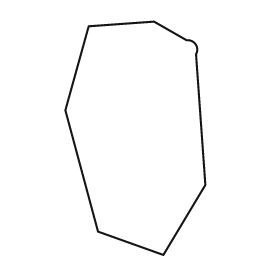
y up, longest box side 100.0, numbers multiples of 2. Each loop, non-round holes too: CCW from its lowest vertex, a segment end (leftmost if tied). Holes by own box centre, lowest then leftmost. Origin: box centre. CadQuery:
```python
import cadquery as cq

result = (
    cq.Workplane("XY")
    .moveTo(12.0, -50.0)
    .lineTo(30.0, -20.0)
    .lineTo(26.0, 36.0)
    .threePointArc((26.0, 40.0), (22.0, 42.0))
    .lineTo(8.0, 50.0)
    .lineTo(-20.0, 48.0)
    .lineTo(-30.0, 12.0)
    .lineTo(-16.0, -40.0)
    .close()
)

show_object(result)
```